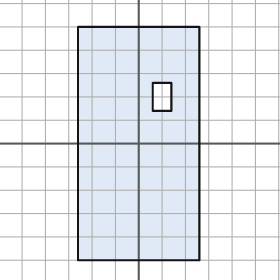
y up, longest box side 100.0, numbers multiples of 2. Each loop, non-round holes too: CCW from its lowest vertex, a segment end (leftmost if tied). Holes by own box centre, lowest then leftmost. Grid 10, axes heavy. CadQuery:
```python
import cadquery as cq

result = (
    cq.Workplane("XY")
    .moveTo(-26.0, -50.0)
    .lineTo(26.0, -50.0)
    .lineTo(26.0, 50.0)
    .lineTo(-26.0, 50.0)
    .close()
    .moveTo(6.0, 14.0)
    .lineTo(14.0, 14.0)
    .lineTo(14.0, 26.0)
    .lineTo(6.0, 26.0)
    .close()
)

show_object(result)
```